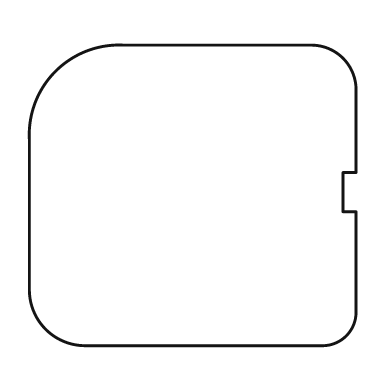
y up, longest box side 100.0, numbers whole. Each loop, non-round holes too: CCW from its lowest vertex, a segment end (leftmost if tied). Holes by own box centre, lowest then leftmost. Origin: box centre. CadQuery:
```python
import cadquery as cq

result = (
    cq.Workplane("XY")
    .moveTo(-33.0, -46.0)
    .lineTo(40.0, -46.0)
    .threePointArc((47.0, -43.0), (50.0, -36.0))
    .lineTo(50.0, -5.0)
    .lineTo(46.0, -5.0)
    .lineTo(46.0, 7.0)
    .lineTo(50.0, 7.0)
    .lineTo(50.0, 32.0)
    .threePointArc((46.0, 42.0), (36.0, 46.0))
    .lineTo(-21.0, 46.0)
    .threePointArc((-42.0, 38.0), (-50.0, 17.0))
    .lineTo(-50.0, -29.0)
    .threePointArc((-45.0, -41.0), (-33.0, -46.0))
    .close()
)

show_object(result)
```